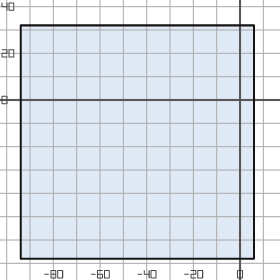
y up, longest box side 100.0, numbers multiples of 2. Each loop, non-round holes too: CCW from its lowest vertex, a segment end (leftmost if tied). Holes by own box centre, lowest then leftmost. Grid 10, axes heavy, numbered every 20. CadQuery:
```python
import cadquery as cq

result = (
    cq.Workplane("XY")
    .moveTo(-94.0, -68.0)
    .lineTo(6.0, -68.0)
    .lineTo(6.0, 32.0)
    .lineTo(-94.0, 32.0)
    .close()
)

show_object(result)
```